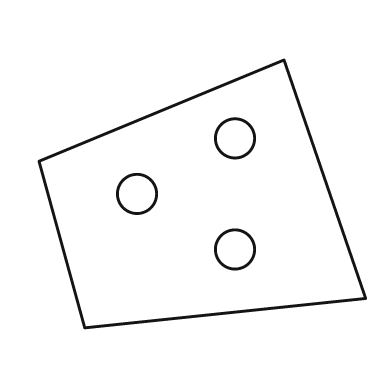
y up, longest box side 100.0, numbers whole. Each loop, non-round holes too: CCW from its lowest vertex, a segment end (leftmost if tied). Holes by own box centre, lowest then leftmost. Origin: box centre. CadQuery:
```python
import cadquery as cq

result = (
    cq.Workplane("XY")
    .moveTo(-36.0, -41.0)
    .lineTo(50.0, -32.0)
    .lineTo(25.0, 41.0)
    .lineTo(-50.0, 10.0)
    .close()
    .moveTo(10.0, -17.0)
    .circle(6.0)
    .moveTo(-20.0, 0.0)
    .circle(6.0)
    .moveTo(10.0, 17.0)
    .circle(6.0)
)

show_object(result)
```